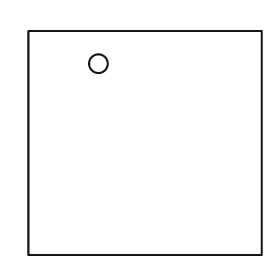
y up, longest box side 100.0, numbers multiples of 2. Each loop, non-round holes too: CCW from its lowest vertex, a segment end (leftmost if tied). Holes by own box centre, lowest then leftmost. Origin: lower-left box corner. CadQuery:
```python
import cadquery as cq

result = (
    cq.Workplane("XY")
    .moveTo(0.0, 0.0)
    .lineTo(100.0, 0.0)
    .lineTo(100.0, 96.0)
    .lineTo(0.0, 96.0)
    .close()
    .moveTo(30.0, 82.0)
    .circle(4.0)
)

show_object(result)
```